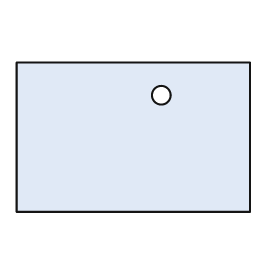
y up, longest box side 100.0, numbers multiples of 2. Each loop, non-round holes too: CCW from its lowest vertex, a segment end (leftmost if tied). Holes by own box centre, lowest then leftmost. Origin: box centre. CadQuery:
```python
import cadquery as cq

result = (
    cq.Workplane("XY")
    .moveTo(-50.0, -32.0)
    .lineTo(50.0, -32.0)
    .lineTo(50.0, 32.0)
    .lineTo(-50.0, 32.0)
    .close()
    .moveTo(12.0, 18.0)
    .circle(4.0)
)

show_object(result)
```